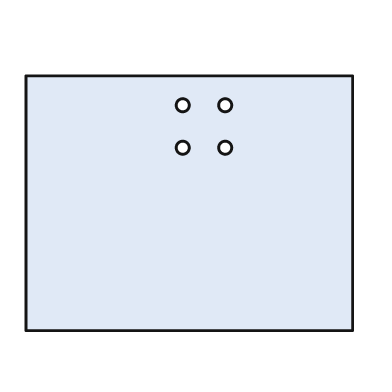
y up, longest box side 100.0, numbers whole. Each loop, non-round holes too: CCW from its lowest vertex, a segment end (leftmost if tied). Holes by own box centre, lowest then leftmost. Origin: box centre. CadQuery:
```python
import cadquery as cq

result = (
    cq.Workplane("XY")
    .moveTo(-50.0, -39.0)
    .lineTo(50.0, -39.0)
    .lineTo(50.0, 39.0)
    .lineTo(-50.0, 39.0)
    .close()
    .moveTo(-2.0, 17.0)
    .circle(2.0)
    .moveTo(11.0, 17.0)
    .circle(2.0)
    .moveTo(-2.0, 30.0)
    .circle(2.0)
    .moveTo(11.0, 30.0)
    .circle(2.0)
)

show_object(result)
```